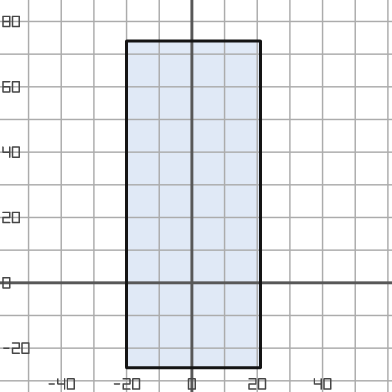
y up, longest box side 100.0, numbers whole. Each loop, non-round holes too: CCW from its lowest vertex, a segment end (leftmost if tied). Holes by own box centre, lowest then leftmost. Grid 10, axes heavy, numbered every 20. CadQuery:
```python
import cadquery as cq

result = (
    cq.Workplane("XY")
    .moveTo(-20.0, -26.0)
    .lineTo(21.0, -26.0)
    .lineTo(21.0, 74.0)
    .lineTo(-20.0, 74.0)
    .close()
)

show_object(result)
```